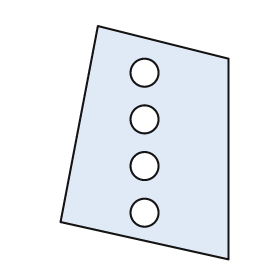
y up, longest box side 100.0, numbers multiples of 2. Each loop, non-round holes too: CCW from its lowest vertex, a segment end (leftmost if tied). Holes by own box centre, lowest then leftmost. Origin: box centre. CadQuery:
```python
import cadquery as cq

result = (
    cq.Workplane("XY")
    .moveTo(36.0, -50.0)
    .lineTo(36.0, 36.0)
    .lineTo(-20.0, 50.0)
    .lineTo(-36.0, -34.0)
    .close()
    .moveTo(0.0, -30.0)
    .circle(6.0)
    .moveTo(0.0, -10.0)
    .circle(6.0)
    .moveTo(0.0, 10.0)
    .circle(6.0)
    .moveTo(0.0, 30.0)
    .circle(6.0)
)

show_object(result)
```